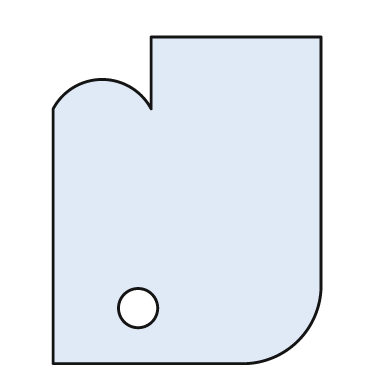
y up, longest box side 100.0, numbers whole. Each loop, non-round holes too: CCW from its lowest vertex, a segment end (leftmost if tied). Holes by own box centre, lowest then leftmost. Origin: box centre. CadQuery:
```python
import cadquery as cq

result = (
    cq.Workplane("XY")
    .moveTo(-41.0, -50.0)
    .lineTo(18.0, -50.0)
    .threePointArc((34.0, -43.0), (41.0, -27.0))
    .lineTo(41.0, 50.0)
    .lineTo(-11.0, 50.0)
    .lineTo(-11.0, 28.0)
    .threePointArc((-26.0, 37.0), (-41.0, 28.0))
    .close()
    .moveTo(-15.0, -33.0)
    .circle(6.0)
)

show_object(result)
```